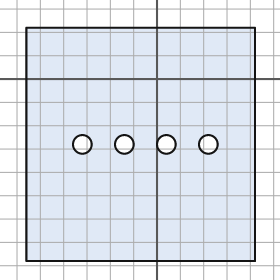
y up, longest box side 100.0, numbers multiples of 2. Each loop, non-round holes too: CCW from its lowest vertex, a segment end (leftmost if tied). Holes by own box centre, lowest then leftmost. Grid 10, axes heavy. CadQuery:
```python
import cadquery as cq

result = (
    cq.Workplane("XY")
    .moveTo(-56.0, -78.0)
    .lineTo(42.0, -78.0)
    .lineTo(42.0, 22.0)
    .lineTo(-56.0, 22.0)
    .close()
    .moveTo(-32.0, -28.0)
    .circle(4.0)
    .moveTo(-14.0, -28.0)
    .circle(4.0)
    .moveTo(4.0, -28.0)
    .circle(4.0)
    .moveTo(22.0, -28.0)
    .circle(4.0)
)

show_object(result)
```